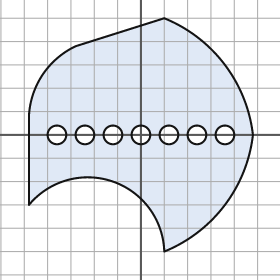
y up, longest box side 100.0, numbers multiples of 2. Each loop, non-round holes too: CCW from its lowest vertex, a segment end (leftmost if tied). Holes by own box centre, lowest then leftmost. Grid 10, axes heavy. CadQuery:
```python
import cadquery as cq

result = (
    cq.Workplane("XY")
    .moveTo(10.0, -50.0)
    .threePointArc((36.0, -30.0), (48.0, 0.0))
    .threePointArc((36.0, 30.0), (10.0, 50.0))
    .lineTo(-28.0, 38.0)
    .threePointArc((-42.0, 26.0), (-48.0, 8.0))
    .lineTo(-48.0, -30.0)
    .threePointArc((-12.0, -20.0), (10.0, -50.0))
    .close()
    .moveTo(-36.0, 0.0)
    .circle(4.0)
    .moveTo(-24.0, 0.0)
    .circle(4.0)
    .moveTo(-12.0, 0.0)
    .circle(4.0)
    .moveTo(0.0, 0.0)
    .circle(4.0)
    .moveTo(12.0, 0.0)
    .circle(4.0)
    .moveTo(24.0, 0.0)
    .circle(4.0)
    .moveTo(36.0, 0.0)
    .circle(4.0)
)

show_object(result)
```